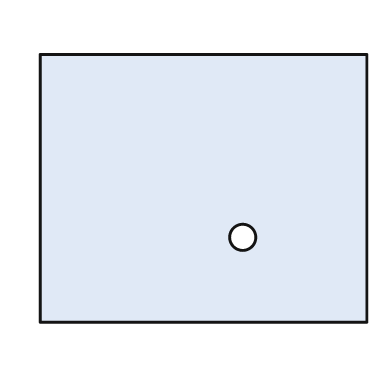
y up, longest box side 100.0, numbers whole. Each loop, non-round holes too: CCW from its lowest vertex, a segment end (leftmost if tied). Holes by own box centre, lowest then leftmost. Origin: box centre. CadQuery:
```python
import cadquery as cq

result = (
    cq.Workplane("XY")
    .moveTo(-50.0, -41.0)
    .lineTo(50.0, -41.0)
    .lineTo(50.0, 41.0)
    .lineTo(-50.0, 41.0)
    .close()
    .moveTo(12.0, -15.0)
    .circle(4.0)
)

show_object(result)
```